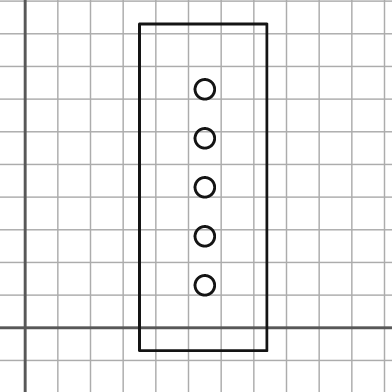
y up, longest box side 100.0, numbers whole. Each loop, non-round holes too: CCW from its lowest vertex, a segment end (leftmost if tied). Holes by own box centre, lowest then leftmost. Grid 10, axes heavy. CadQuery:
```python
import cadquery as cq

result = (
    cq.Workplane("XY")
    .moveTo(35.0, -7.0)
    .lineTo(74.0, -7.0)
    .lineTo(74.0, 93.0)
    .lineTo(35.0, 93.0)
    .close()
    .moveTo(55.0, 13.0)
    .circle(3.0)
    .moveTo(55.0, 28.0)
    .circle(3.0)
    .moveTo(55.0, 43.0)
    .circle(3.0)
    .moveTo(55.0, 58.0)
    .circle(3.0)
    .moveTo(55.0, 73.0)
    .circle(3.0)
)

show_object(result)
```